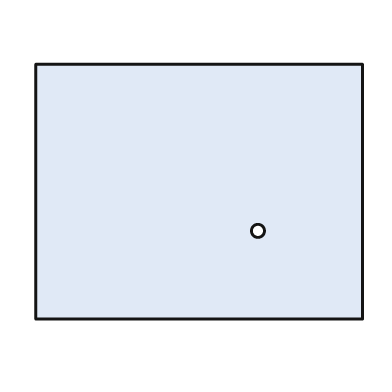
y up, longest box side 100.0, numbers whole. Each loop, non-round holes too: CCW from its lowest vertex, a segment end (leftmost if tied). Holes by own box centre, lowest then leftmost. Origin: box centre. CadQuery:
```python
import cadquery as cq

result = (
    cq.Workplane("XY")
    .moveTo(-50.0, -39.0)
    .lineTo(50.0, -39.0)
    .lineTo(50.0, 39.0)
    .lineTo(-50.0, 39.0)
    .close()
    .moveTo(18.0, -12.0)
    .circle(2.0)
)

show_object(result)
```